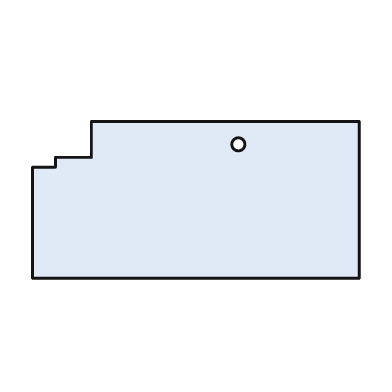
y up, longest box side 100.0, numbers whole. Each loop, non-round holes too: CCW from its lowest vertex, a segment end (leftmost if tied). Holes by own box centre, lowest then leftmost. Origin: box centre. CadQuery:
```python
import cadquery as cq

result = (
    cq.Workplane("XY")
    .moveTo(-50.0, -24.0)
    .lineTo(50.0, -24.0)
    .lineTo(50.0, 24.0)
    .lineTo(-32.0, 24.0)
    .lineTo(-32.0, 13.0)
    .lineTo(-43.0, 13.0)
    .lineTo(-43.0, 10.0)
    .lineTo(-50.0, 10.0)
    .close()
    .moveTo(13.0, 17.0)
    .circle(2.0)
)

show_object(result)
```